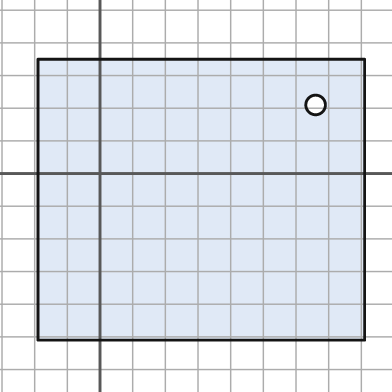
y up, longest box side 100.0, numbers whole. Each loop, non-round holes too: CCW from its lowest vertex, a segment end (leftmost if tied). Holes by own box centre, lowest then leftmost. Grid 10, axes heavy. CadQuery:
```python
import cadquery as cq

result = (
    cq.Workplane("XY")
    .moveTo(-19.0, -51.0)
    .lineTo(81.0, -51.0)
    .lineTo(81.0, 35.0)
    .lineTo(-19.0, 35.0)
    .close()
    .moveTo(66.0, 21.0)
    .circle(3.0)
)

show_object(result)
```